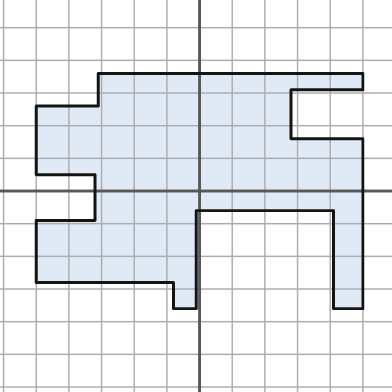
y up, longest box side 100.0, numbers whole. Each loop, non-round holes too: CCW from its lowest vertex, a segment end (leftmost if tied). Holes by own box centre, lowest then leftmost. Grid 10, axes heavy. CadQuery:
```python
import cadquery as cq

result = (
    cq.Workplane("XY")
    .moveTo(-8.0, -36.0)
    .lineTo(-1.0, -36.0)
    .lineTo(-1.0, -6.0)
    .lineTo(41.0, -6.0)
    .lineTo(41.0, -36.0)
    .lineTo(50.0, -36.0)
    .lineTo(50.0, 16.0)
    .lineTo(28.0, 16.0)
    .lineTo(28.0, 31.0)
    .lineTo(50.0, 31.0)
    .lineTo(50.0, 36.0)
    .lineTo(-31.0, 36.0)
    .lineTo(-31.0, 26.0)
    .lineTo(-50.0, 26.0)
    .lineTo(-50.0, 5.0)
    .lineTo(-32.0, 5.0)
    .lineTo(-32.0, -9.0)
    .lineTo(-50.0, -9.0)
    .lineTo(-50.0, -28.0)
    .lineTo(-8.0, -28.0)
    .close()
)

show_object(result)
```